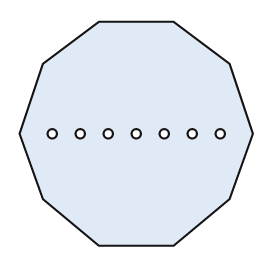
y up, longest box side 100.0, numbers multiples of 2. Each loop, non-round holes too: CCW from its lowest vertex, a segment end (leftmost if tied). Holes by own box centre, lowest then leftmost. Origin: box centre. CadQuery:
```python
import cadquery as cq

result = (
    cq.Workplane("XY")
    .moveTo(-16.0, -48.0)
    .lineTo(16.0, -48.0)
    .lineTo(40.0, -28.0)
    .lineTo(50.0, 0.0)
    .lineTo(40.0, 30.0)
    .lineTo(16.0, 48.0)
    .lineTo(-16.0, 48.0)
    .lineTo(-40.0, 30.0)
    .lineTo(-50.0, 0.0)
    .lineTo(-40.0, -28.0)
    .close()
    .moveTo(-36.0, 0.0)
    .circle(2.0)
    .moveTo(-24.0, 0.0)
    .circle(2.0)
    .moveTo(-12.0, 0.0)
    .circle(2.0)
    .moveTo(0.0, 0.0)
    .circle(2.0)
    .moveTo(12.0, 0.0)
    .circle(2.0)
    .moveTo(24.0, 0.0)
    .circle(2.0)
    .moveTo(36.0, 0.0)
    .circle(2.0)
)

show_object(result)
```